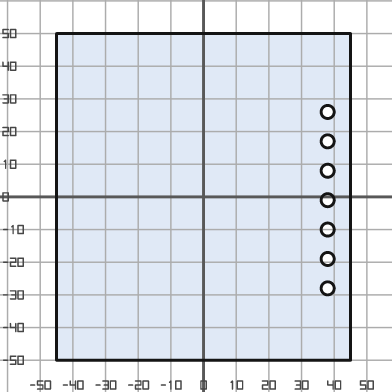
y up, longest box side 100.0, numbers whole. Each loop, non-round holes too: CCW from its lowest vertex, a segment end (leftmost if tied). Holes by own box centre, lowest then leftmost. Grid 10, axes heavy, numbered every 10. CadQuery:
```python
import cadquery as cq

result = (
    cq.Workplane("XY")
    .moveTo(-45.0, -50.0)
    .lineTo(45.0, -50.0)
    .lineTo(45.0, 50.0)
    .lineTo(-45.0, 50.0)
    .close()
    .moveTo(38.0, -28.0)
    .circle(2.0)
    .moveTo(38.0, -19.0)
    .circle(2.0)
    .moveTo(38.0, -10.0)
    .circle(2.0)
    .moveTo(38.0, -1.0)
    .circle(2.0)
    .moveTo(38.0, 8.0)
    .circle(2.0)
    .moveTo(38.0, 17.0)
    .circle(2.0)
    .moveTo(38.0, 26.0)
    .circle(2.0)
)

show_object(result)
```